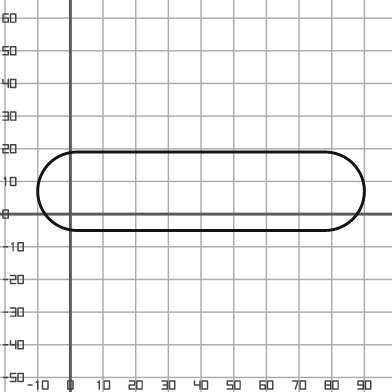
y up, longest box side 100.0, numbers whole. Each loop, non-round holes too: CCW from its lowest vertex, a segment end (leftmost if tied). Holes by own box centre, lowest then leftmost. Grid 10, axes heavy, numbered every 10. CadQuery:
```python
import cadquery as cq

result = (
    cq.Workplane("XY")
    .moveTo(2.0, -5.0)
    .lineTo(78.0, -5.0)
    .threePointArc((90.0, 7.0), (78.0, 19.0))
    .lineTo(2.0, 19.0)
    .threePointArc((-10.0, 7.0), (2.0, -5.0))
    .close()
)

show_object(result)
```